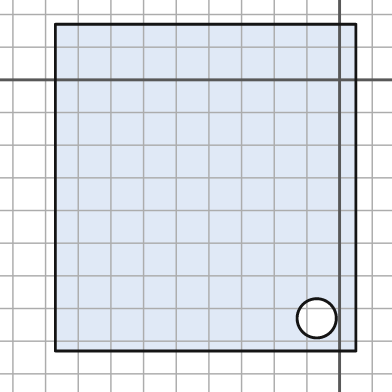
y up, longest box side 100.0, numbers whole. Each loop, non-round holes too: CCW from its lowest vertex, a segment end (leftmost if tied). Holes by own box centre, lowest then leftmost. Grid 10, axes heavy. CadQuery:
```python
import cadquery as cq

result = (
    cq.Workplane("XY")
    .moveTo(-87.0, -83.0)
    .lineTo(5.0, -83.0)
    .lineTo(5.0, 17.0)
    .lineTo(-87.0, 17.0)
    .close()
    .moveTo(-7.0, -73.0)
    .circle(6.0)
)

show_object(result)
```